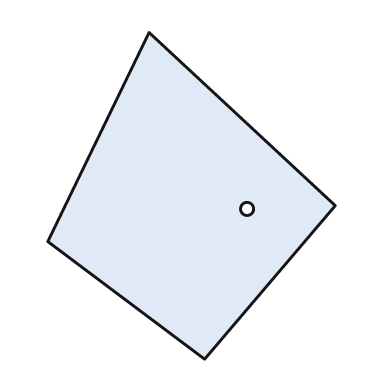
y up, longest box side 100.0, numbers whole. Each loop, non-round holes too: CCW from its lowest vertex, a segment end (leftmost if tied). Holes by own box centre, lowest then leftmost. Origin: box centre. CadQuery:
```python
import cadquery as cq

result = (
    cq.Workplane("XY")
    .moveTo(4.0, -50.0)
    .lineTo(44.0, -3.0)
    .lineTo(-13.0, 50.0)
    .lineTo(-44.0, -14.0)
    .close()
    .moveTo(17.0, -4.0)
    .circle(2.0)
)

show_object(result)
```